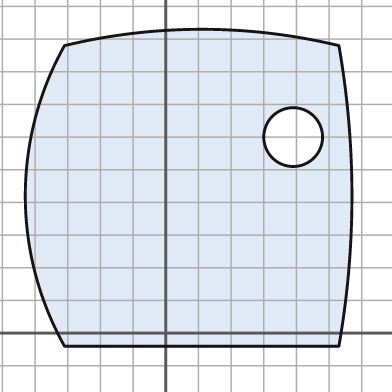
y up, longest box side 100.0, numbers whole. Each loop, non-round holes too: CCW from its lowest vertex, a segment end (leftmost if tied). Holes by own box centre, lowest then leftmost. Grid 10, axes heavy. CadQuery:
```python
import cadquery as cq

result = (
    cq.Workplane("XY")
    .moveTo(-31.0, -4.0)
    .lineTo(53.0, -4.0)
    .threePointArc((57.0, 42.0), (53.0, 88.0))
    .threePointArc((11.0, 93.0), (-31.0, 88.0))
    .threePointArc((-43.0, 42.0), (-31.0, -4.0))
    .close()
    .moveTo(39.0, 60.0)
    .circle(9.0)
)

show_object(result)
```